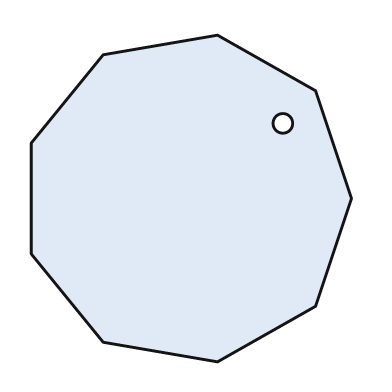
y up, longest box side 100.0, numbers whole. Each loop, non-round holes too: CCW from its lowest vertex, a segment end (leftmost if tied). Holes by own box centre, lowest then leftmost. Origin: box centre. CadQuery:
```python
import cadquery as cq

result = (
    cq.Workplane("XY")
    .moveTo(8.0, -50.0)
    .lineTo(38.0, -33.0)
    .lineTo(49.0, 0.0)
    .lineTo(38.0, 33.0)
    .lineTo(8.0, 50.0)
    .lineTo(-27.0, 44.0)
    .lineTo(-49.0, 17.0)
    .lineTo(-49.0, -17.0)
    .lineTo(-27.0, -44.0)
    .close()
    .moveTo(28.0, 23.0)
    .circle(3.0)
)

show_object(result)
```